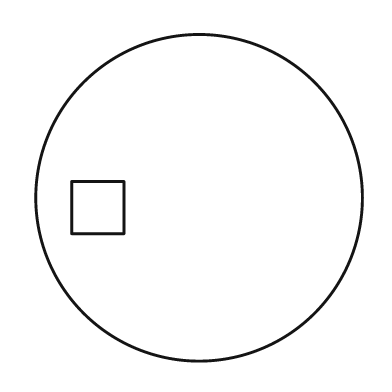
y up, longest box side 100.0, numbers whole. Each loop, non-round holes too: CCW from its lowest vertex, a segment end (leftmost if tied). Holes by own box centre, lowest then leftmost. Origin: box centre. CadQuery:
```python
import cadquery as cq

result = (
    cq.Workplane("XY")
    .moveTo(0.0, 0.0)
    .circle(50.0)
    .moveTo(-39.0, -11.0)
    .lineTo(-23.0, -11.0)
    .lineTo(-23.0, 5.0)
    .lineTo(-39.0, 5.0)
    .close()
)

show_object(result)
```